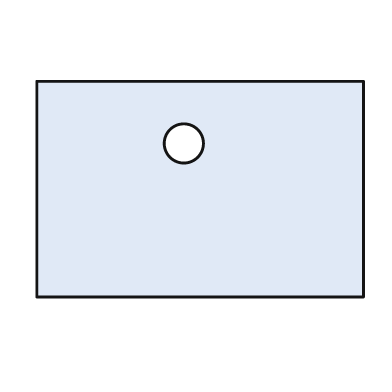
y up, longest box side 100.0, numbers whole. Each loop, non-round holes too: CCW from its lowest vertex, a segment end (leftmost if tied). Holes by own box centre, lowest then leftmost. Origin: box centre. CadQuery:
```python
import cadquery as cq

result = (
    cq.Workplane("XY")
    .moveTo(-50.0, -33.0)
    .lineTo(50.0, -33.0)
    .lineTo(50.0, 33.0)
    .lineTo(-50.0, 33.0)
    .close()
    .moveTo(-5.0, 14.0)
    .circle(6.0)
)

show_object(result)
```